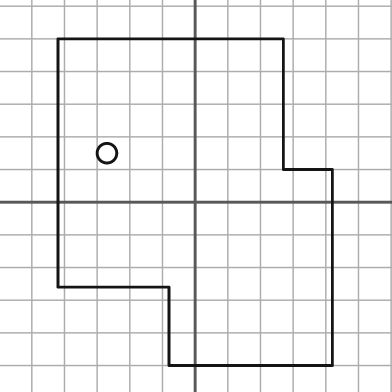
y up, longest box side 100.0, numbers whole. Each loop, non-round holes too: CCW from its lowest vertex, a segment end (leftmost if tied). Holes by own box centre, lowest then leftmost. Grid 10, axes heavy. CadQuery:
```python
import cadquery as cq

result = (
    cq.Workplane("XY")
    .moveTo(-8.0, -50.0)
    .lineTo(42.0, -50.0)
    .lineTo(42.0, 10.0)
    .lineTo(27.0, 10.0)
    .lineTo(27.0, 50.0)
    .lineTo(-42.0, 50.0)
    .lineTo(-42.0, -26.0)
    .lineTo(-8.0, -26.0)
    .close()
    .moveTo(-27.0, 15.0)
    .circle(3.0)
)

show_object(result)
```